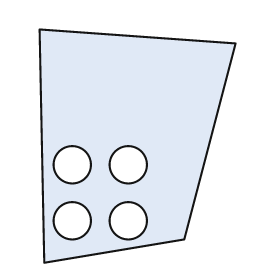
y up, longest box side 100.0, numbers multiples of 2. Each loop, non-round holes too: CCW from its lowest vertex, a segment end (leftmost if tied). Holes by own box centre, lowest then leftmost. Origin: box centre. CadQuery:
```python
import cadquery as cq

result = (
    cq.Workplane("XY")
    .moveTo(-40.0, -50.0)
    .lineTo(20.0, -40.0)
    .lineTo(42.0, 44.0)
    .lineTo(-42.0, 50.0)
    .close()
    .moveTo(-28.0, -32.0)
    .circle(8.0)
    .moveTo(-4.0, -32.0)
    .circle(8.0)
    .moveTo(-28.0, -8.0)
    .circle(8.0)
    .moveTo(-4.0, -8.0)
    .circle(8.0)
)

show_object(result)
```